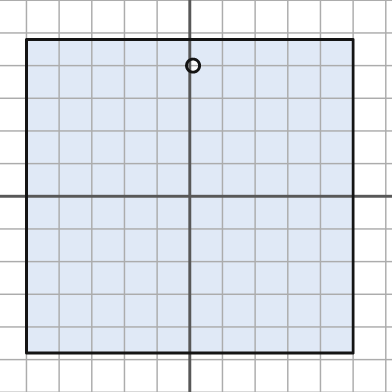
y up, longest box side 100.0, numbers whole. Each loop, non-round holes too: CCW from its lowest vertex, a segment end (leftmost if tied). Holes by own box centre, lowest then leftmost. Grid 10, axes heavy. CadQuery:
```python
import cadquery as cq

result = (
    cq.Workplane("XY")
    .moveTo(-50.0, -48.0)
    .lineTo(50.0, -48.0)
    .lineTo(50.0, 48.0)
    .lineTo(-50.0, 48.0)
    .close()
    .moveTo(1.0, 40.0)
    .circle(2.0)
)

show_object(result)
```